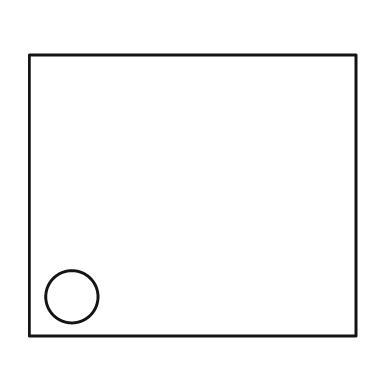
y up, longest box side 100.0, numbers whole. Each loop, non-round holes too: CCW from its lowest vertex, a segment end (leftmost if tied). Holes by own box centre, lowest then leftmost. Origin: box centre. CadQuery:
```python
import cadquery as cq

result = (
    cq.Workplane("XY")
    .moveTo(-50.0, -43.0)
    .lineTo(50.0, -43.0)
    .lineTo(50.0, 43.0)
    .lineTo(-50.0, 43.0)
    .close()
    .moveTo(-37.0, -31.0)
    .circle(8.0)
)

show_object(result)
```